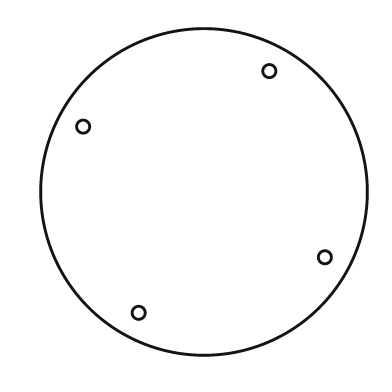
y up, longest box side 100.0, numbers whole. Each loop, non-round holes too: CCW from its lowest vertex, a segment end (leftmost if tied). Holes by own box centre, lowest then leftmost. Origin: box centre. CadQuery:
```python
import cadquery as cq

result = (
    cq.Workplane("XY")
    .moveTo(0.0, 0.0)
    .circle(50.0)
    .moveTo(-20.0, -37.0)
    .circle(2.0)
    .moveTo(37.0, -20.0)
    .circle(2.0)
    .moveTo(-37.0, 20.0)
    .circle(2.0)
    .moveTo(20.0, 37.0)
    .circle(2.0)
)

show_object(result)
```